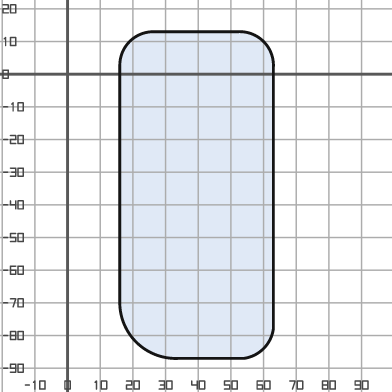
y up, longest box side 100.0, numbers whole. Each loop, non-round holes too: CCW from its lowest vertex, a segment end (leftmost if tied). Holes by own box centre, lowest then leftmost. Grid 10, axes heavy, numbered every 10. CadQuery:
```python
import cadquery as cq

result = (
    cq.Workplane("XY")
    .moveTo(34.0, -87.0)
    .lineTo(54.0, -87.0)
    .threePointArc((60.0, -84.0), (63.0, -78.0))
    .lineTo(63.0, 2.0)
    .threePointArc((60.0, 10.0), (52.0, 13.0))
    .lineTo(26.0, 13.0)
    .threePointArc((19.0, 10.0), (16.0, 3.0))
    .lineTo(16.0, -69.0)
    .threePointArc((21.0, -82.0), (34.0, -87.0))
    .close()
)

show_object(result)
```